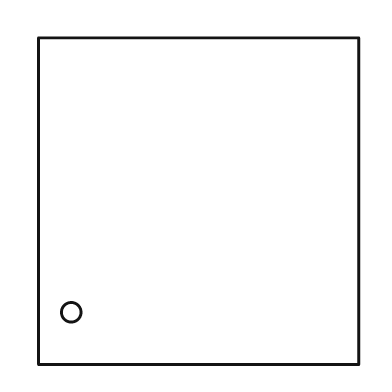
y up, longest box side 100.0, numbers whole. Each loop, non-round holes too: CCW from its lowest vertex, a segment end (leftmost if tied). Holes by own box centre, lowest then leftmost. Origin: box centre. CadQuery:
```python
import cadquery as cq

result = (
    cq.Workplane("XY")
    .moveTo(-49.0, -50.0)
    .lineTo(49.0, -50.0)
    .lineTo(49.0, 50.0)
    .lineTo(-49.0, 50.0)
    .close()
    .moveTo(-39.0, -34.0)
    .circle(3.0)
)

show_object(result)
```